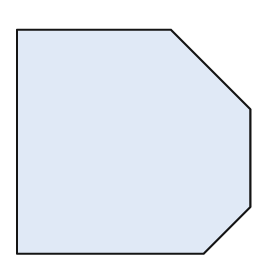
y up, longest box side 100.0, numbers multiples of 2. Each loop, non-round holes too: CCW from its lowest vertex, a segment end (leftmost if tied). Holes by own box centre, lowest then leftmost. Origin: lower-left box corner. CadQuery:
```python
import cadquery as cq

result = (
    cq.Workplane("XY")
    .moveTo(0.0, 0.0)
    .lineTo(80.0, 0.0)
    .lineTo(100.0, 20.0)
    .lineTo(100.0, 62.0)
    .lineTo(66.0, 96.0)
    .lineTo(0.0, 96.0)
    .close()
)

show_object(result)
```